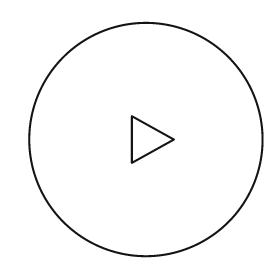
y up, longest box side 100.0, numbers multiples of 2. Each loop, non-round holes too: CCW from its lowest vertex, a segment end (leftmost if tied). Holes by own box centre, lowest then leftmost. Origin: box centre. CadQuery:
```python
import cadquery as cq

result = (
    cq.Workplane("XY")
    .moveTo(0.0, 0.0)
    .circle(50.0)
    .moveTo(-6.0, -10.0)
    .lineTo(12.0, 0.0)
    .lineTo(-6.0, 10.0)
    .close()
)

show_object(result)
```